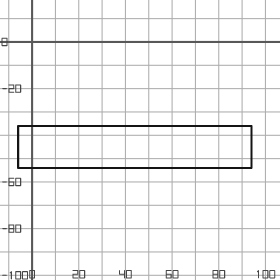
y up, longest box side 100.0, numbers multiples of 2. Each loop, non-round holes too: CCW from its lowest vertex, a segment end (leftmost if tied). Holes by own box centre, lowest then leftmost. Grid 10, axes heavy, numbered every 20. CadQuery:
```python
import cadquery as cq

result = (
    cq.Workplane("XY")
    .moveTo(-6.0, -54.0)
    .lineTo(94.0, -54.0)
    .lineTo(94.0, -36.0)
    .lineTo(-6.0, -36.0)
    .close()
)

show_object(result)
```